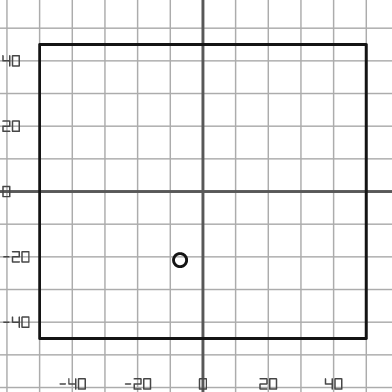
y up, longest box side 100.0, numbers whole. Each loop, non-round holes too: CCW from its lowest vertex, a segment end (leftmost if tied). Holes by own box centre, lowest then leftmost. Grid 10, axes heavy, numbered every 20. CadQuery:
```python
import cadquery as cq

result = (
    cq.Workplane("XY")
    .moveTo(-50.0, -45.0)
    .lineTo(50.0, -45.0)
    .lineTo(50.0, 45.0)
    .lineTo(-50.0, 45.0)
    .close()
    .moveTo(-7.0, -21.0)
    .circle(2.0)
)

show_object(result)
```